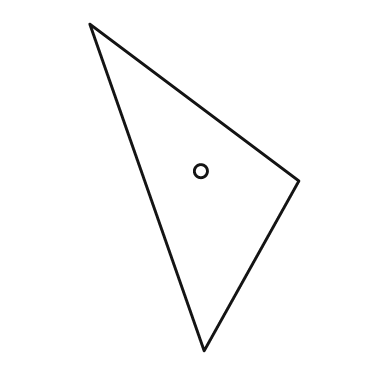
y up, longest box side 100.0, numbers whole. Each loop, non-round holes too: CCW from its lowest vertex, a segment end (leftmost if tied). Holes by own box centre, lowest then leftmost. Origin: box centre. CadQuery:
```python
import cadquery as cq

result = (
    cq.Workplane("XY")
    .moveTo(3.0, -50.0)
    .lineTo(32.0, 2.0)
    .lineTo(-32.0, 50.0)
    .close()
    .moveTo(2.0, 5.0)
    .circle(2.0)
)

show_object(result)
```